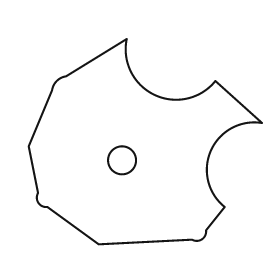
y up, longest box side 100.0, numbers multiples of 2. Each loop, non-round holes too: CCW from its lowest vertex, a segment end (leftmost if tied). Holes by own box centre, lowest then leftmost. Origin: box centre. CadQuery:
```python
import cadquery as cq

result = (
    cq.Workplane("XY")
    .moveTo(-20.0, -44.0)
    .lineTo(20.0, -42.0)
    .threePointArc((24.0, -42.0), (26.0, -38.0))
    .lineTo(34.0, -28.0)
    .threePointArc((28.0, -4.0), (50.0, 8.0))
    .lineTo(30.0, 26.0)
    .threePointArc((4.0, 20.0), (-8.0, 44.0))
    .lineTo(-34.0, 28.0)
    .threePointArc((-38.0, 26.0), (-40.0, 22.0))
    .lineTo(-50.0, -2.0)
    .lineTo(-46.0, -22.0)
    .threePointArc((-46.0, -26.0), (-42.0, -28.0))
    .close()
    .moveTo(-10.0, -8.0)
    .circle(6.0)
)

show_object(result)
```